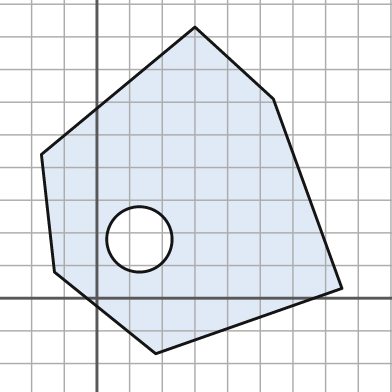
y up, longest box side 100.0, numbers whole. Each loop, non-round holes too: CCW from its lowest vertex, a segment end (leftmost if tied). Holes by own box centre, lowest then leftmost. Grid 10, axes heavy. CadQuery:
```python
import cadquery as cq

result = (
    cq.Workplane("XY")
    .moveTo(18.0, -17.0)
    .lineTo(75.0, 3.0)
    .lineTo(54.0, 61.0)
    .lineTo(30.0, 83.0)
    .lineTo(-17.0, 44.0)
    .lineTo(-13.0, 8.0)
    .close()
    .moveTo(13.0, 18.0)
    .circle(10.0)
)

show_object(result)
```